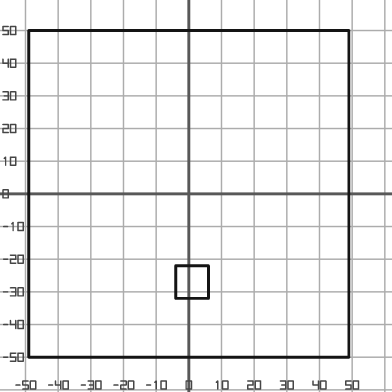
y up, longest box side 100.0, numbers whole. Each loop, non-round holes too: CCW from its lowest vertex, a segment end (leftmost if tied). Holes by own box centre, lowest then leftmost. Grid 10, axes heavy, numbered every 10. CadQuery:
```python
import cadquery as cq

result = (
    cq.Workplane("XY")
    .moveTo(-49.0, -50.0)
    .lineTo(49.0, -50.0)
    .lineTo(49.0, 50.0)
    .lineTo(-49.0, 50.0)
    .close()
    .moveTo(-4.0, -32.0)
    .lineTo(6.0, -32.0)
    .lineTo(6.0, -22.0)
    .lineTo(-4.0, -22.0)
    .close()
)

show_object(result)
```